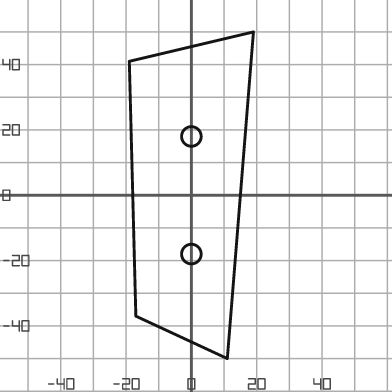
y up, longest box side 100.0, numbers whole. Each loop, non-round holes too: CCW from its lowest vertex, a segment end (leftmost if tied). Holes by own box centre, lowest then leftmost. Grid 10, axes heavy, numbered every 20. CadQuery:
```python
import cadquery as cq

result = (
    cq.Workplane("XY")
    .moveTo(11.0, -50.0)
    .lineTo(19.0, 50.0)
    .lineTo(-19.0, 41.0)
    .lineTo(-17.0, -37.0)
    .close()
    .moveTo(0.0, -18.0)
    .circle(3.0)
    .moveTo(0.0, 18.0)
    .circle(3.0)
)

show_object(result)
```